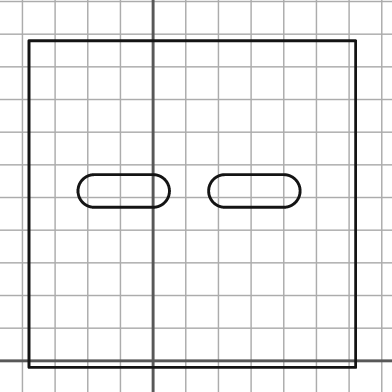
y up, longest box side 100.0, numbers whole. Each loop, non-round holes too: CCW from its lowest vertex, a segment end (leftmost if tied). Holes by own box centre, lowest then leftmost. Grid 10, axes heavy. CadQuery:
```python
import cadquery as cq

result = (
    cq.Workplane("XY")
    .moveTo(-38.0, -2.0)
    .lineTo(62.0, -2.0)
    .lineTo(62.0, 98.0)
    .lineTo(-38.0, 98.0)
    .close()
    .moveTo(-18.0, 47.0)
    .lineTo(0.0, 47.0)
    .threePointArc((5.0, 52.0), (0.0, 57.0))
    .lineTo(-18.0, 57.0)
    .threePointArc((-23.0, 52.0), (-18.0, 47.0))
    .close()
    .moveTo(22.0, 47.0)
    .lineTo(40.0, 47.0)
    .threePointArc((45.0, 52.0), (40.0, 57.0))
    .lineTo(22.0, 57.0)
    .threePointArc((17.0, 52.0), (22.0, 47.0))
    .close()
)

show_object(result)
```